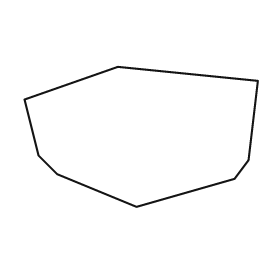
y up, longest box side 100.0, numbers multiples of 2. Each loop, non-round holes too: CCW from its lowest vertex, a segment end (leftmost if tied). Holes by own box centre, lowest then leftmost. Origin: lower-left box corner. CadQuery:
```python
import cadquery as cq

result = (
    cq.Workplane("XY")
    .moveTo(48.0, 0.0)
    .lineTo(90.0, 12.0)
    .lineTo(96.0, 20.0)
    .lineTo(100.0, 54.0)
    .lineTo(40.0, 60.0)
    .lineTo(0.0, 46.0)
    .lineTo(6.0, 22.0)
    .lineTo(14.0, 14.0)
    .close()
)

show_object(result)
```